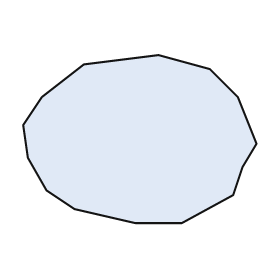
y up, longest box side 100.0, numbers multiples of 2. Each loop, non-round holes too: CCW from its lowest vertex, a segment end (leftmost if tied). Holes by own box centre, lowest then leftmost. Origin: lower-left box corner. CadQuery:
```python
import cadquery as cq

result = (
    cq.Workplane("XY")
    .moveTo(48.0, 0.0)
    .lineTo(68.0, 0.0)
    .lineTo(90.0, 12.0)
    .lineTo(94.0, 24.0)
    .lineTo(100.0, 34.0)
    .lineTo(92.0, 54.0)
    .lineTo(80.0, 66.0)
    .lineTo(58.0, 72.0)
    .lineTo(26.0, 68.0)
    .lineTo(8.0, 54.0)
    .lineTo(0.0, 42.0)
    .lineTo(2.0, 28.0)
    .lineTo(10.0, 14.0)
    .lineTo(22.0, 6.0)
    .close()
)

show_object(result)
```